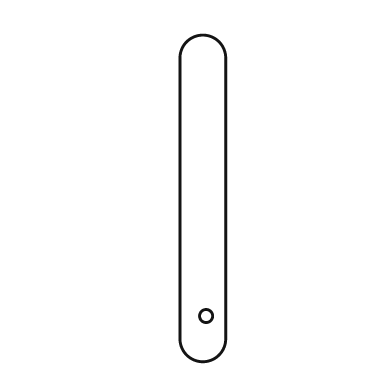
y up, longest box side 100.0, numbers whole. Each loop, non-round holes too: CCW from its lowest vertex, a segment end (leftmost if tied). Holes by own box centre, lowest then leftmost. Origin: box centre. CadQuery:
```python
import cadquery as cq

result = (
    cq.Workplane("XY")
    .moveTo(-7.0, -43.0)
    .threePointArc((0.0, -50.0), (7.0, -43.0))
    .lineTo(7.0, 43.0)
    .threePointArc((0.0, 50.0), (-7.0, 43.0))
    .close()
    .moveTo(1.0, -36.0)
    .circle(2.0)
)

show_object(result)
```